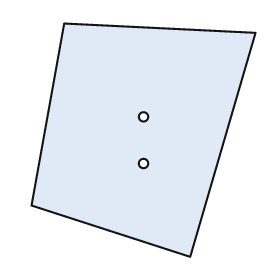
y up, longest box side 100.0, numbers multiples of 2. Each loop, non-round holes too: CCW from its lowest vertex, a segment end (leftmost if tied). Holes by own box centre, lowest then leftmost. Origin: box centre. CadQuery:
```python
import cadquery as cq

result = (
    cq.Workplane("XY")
    .moveTo(20.0, -50.0)
    .lineTo(48.0, 46.0)
    .lineTo(-34.0, 50.0)
    .lineTo(-48.0, -28.0)
    .close()
    .moveTo(0.0, -10.0)
    .circle(2.0)
    .moveTo(0.0, 10.0)
    .circle(2.0)
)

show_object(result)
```